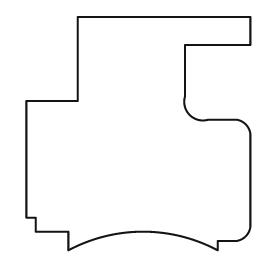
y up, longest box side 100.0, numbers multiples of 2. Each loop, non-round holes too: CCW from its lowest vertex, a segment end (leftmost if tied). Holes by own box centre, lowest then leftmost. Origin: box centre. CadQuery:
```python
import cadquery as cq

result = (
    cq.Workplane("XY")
    .moveTo(-30.0, -50.0)
    .threePointArc((2.0, -42.0), (34.0, -50.0))
    .lineTo(34.0, -46.0)
    .lineTo(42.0, -46.0)
    .threePointArc((46.0, -44.0), (48.0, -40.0))
    .lineTo(48.0, 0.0)
    .threePointArc((46.0, 4.0), (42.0, 6.0))
    .lineTo(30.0, 6.0)
    .threePointArc((22.0, 8.0), (20.0, 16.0))
    .lineTo(20.0, 38.0)
    .lineTo(48.0, 38.0)
    .lineTo(48.0, 50.0)
    .lineTo(-26.0, 50.0)
    .lineTo(-26.0, 14.0)
    .lineTo(-48.0, 14.0)
    .lineTo(-48.0, -36.0)
    .lineTo(-44.0, -36.0)
    .lineTo(-44.0, -42.0)
    .lineTo(-30.0, -42.0)
    .close()
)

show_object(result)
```